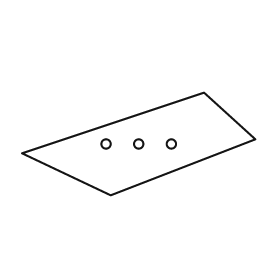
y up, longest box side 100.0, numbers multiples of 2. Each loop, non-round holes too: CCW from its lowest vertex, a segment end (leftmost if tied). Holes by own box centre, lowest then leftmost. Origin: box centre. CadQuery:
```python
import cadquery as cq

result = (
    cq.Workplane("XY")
    .moveTo(-12.0, -22.0)
    .lineTo(50.0, 2.0)
    .lineTo(28.0, 22.0)
    .lineTo(-50.0, -4.0)
    .close()
    .moveTo(-14.0, 0.0)
    .circle(2.0)
    .moveTo(0.0, 0.0)
    .circle(2.0)
    .moveTo(14.0, 0.0)
    .circle(2.0)
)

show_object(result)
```